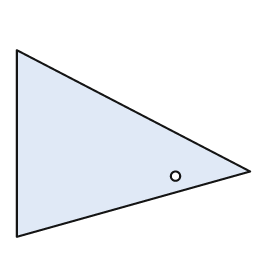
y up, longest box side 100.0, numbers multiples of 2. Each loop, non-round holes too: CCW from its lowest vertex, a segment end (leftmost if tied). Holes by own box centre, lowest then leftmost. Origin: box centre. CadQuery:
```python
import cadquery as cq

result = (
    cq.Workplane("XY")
    .moveTo(-50.0, -40.0)
    .lineTo(50.0, -12.0)
    .lineTo(-50.0, 40.0)
    .close()
    .moveTo(18.0, -14.0)
    .circle(2.0)
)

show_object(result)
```